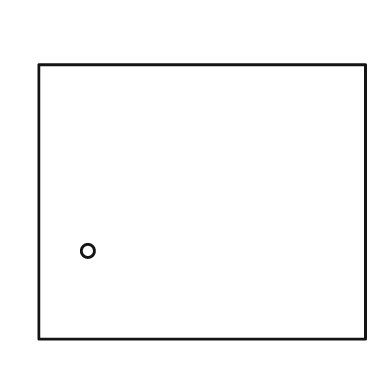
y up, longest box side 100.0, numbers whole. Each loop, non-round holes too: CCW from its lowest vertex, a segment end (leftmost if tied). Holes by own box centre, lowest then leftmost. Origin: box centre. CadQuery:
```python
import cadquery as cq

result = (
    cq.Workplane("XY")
    .moveTo(-50.0, -42.0)
    .lineTo(50.0, -42.0)
    .lineTo(50.0, 42.0)
    .lineTo(-50.0, 42.0)
    .close()
    .moveTo(-35.0, -15.0)
    .circle(2.0)
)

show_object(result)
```